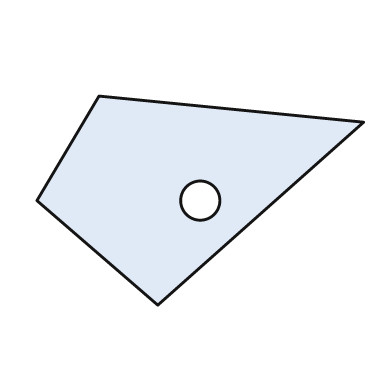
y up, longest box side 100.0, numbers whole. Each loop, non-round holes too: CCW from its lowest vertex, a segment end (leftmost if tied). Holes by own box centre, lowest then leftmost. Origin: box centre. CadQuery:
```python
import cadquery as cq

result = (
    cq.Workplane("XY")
    .moveTo(-13.0, -32.0)
    .lineTo(50.0, 24.0)
    .lineTo(-31.0, 32.0)
    .lineTo(-50.0, 0.0)
    .close()
    .moveTo(0.0, 0.0)
    .circle(6.0)
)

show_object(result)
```